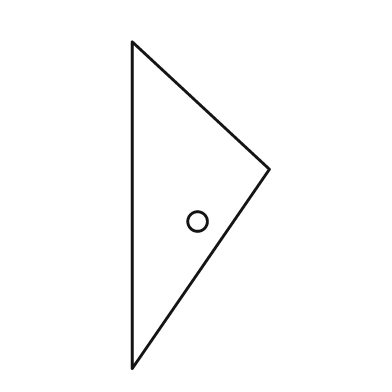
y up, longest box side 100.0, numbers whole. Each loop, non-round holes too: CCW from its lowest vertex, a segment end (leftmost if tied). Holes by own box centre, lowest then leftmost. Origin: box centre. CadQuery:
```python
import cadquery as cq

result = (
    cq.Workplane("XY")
    .moveTo(-21.0, -50.0)
    .lineTo(21.0, 11.0)
    .lineTo(-21.0, 50.0)
    .close()
    .moveTo(-1.0, -5.0)
    .circle(3.0)
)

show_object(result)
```